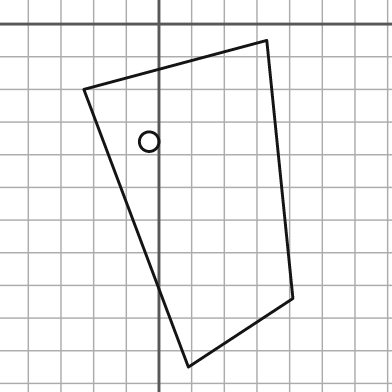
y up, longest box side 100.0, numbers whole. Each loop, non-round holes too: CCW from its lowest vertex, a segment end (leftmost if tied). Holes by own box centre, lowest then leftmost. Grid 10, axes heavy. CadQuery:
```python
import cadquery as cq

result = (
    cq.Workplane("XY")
    .moveTo(9.0, -105.0)
    .lineTo(41.0, -84.0)
    .lineTo(33.0, -5.0)
    .lineTo(-23.0, -20.0)
    .close()
    .moveTo(-3.0, -36.0)
    .circle(3.0)
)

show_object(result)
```